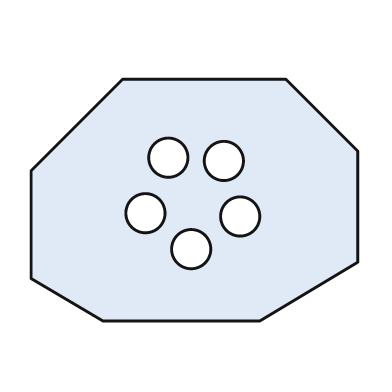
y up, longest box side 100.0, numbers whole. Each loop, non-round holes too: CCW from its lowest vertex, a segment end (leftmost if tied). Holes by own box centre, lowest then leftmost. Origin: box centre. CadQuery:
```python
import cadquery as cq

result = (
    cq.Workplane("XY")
    .moveTo(-28.0, -37.0)
    .lineTo(20.0, -37.0)
    .lineTo(50.0, -19.0)
    .lineTo(50.0, 15.0)
    .lineTo(28.0, 37.0)
    .lineTo(-22.0, 37.0)
    .lineTo(-50.0, 9.0)
    .lineTo(-50.0, -24.0)
    .close()
    .moveTo(-1.0, -15.0)
    .circle(6.0)
    .moveTo(14.0, -5.0)
    .circle(6.0)
    .moveTo(-15.0, -4.0)
    .circle(6.0)
    .moveTo(9.0, 12.0)
    .circle(6.0)
    .moveTo(-8.0, 13.0)
    .circle(6.0)
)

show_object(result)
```